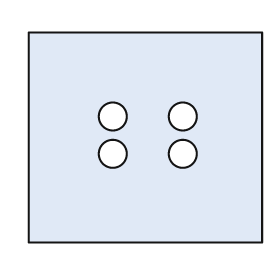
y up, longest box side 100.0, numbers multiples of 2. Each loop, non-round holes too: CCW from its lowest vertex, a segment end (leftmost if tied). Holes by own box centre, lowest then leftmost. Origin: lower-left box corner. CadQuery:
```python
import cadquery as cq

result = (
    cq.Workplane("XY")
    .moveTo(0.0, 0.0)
    .lineTo(100.0, 0.0)
    .lineTo(100.0, 90.0)
    .lineTo(0.0, 90.0)
    .close()
    .moveTo(36.0, 38.0)
    .circle(6.0)
    .moveTo(66.0, 38.0)
    .circle(6.0)
    .moveTo(36.0, 54.0)
    .circle(6.0)
    .moveTo(66.0, 54.0)
    .circle(6.0)
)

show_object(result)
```